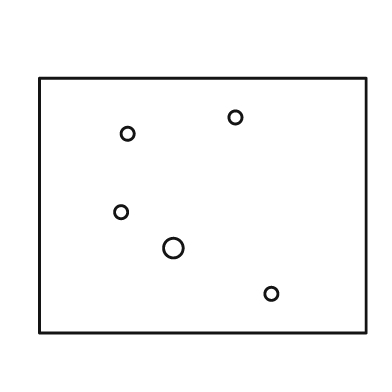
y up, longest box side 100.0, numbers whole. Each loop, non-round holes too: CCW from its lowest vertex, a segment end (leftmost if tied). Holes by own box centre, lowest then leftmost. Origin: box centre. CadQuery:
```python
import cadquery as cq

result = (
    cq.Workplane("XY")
    .moveTo(-50.0, -39.0)
    .lineTo(50.0, -39.0)
    .lineTo(50.0, 39.0)
    .lineTo(-50.0, 39.0)
    .close()
    .moveTo(21.0, -27.0)
    .circle(2.0)
    .moveTo(-9.0, -13.0)
    .circle(3.0)
    .moveTo(-25.0, -2.0)
    .circle(2.0)
    .moveTo(-23.0, 22.0)
    .circle(2.0)
    .moveTo(10.0, 27.0)
    .circle(2.0)
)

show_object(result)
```